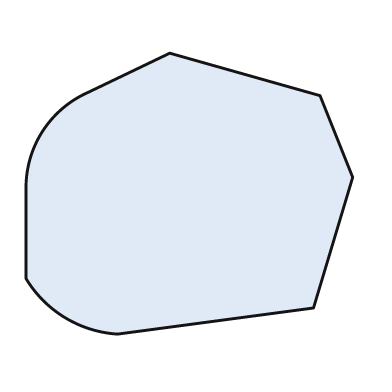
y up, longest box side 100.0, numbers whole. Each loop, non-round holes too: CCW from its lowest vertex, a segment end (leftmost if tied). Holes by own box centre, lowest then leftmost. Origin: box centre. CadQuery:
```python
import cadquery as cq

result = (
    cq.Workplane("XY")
    .moveTo(-22.0, -43.0)
    .lineTo(38.0, -35.0)
    .lineTo(50.0, 5.0)
    .lineTo(40.0, 30.0)
    .lineTo(-6.0, 43.0)
    .lineTo(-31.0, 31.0)
    .threePointArc((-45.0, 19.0), (-50.0, 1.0))
    .lineTo(-50.0, -26.0)
    .threePointArc((-38.0, -38.0), (-22.0, -43.0))
    .close()
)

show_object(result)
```